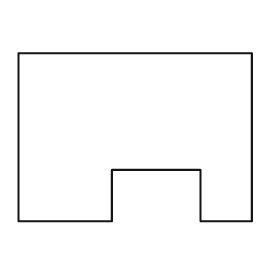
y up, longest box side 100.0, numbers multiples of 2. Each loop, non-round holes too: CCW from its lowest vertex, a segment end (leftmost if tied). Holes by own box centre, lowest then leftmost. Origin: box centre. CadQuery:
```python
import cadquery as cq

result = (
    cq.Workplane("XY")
    .moveTo(-50.0, -36.0)
    .lineTo(-10.0, -36.0)
    .lineTo(-10.0, -14.0)
    .lineTo(28.0, -14.0)
    .lineTo(28.0, -36.0)
    .lineTo(50.0, -36.0)
    .lineTo(50.0, 36.0)
    .lineTo(-50.0, 36.0)
    .close()
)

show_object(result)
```